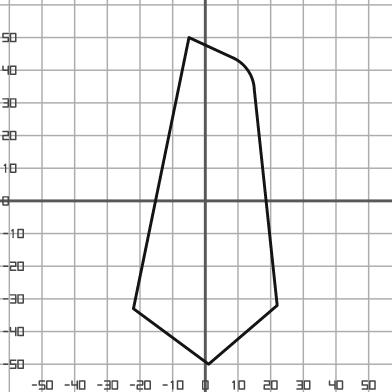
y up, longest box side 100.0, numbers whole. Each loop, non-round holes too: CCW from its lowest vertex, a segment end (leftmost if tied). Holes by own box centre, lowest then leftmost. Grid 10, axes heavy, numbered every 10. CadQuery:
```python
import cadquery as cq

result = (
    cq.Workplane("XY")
    .moveTo(1.0, -50.0)
    .lineTo(22.0, -32.0)
    .lineTo(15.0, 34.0)
    .threePointArc((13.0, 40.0), (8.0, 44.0))
    .lineTo(-5.0, 50.0)
    .lineTo(-22.0, -33.0)
    .close()
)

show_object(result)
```